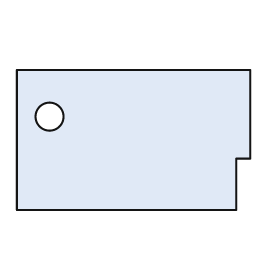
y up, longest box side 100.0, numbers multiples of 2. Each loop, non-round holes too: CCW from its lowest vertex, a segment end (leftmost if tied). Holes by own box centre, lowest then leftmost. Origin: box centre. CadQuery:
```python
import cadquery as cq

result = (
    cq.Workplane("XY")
    .moveTo(-50.0, -30.0)
    .lineTo(44.0, -30.0)
    .lineTo(44.0, -8.0)
    .lineTo(50.0, -8.0)
    .lineTo(50.0, 30.0)
    .lineTo(-50.0, 30.0)
    .close()
    .moveTo(-36.0, 10.0)
    .circle(6.0)
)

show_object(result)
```